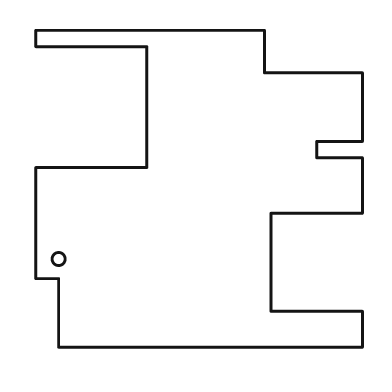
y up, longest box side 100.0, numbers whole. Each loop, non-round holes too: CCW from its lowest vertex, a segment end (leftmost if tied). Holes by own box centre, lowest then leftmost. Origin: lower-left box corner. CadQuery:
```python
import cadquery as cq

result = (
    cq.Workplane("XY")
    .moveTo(7.0, 0.0)
    .lineTo(100.0, 0.0)
    .lineTo(100.0, 11.0)
    .lineTo(72.0, 11.0)
    .lineTo(72.0, 41.0)
    .lineTo(100.0, 41.0)
    .lineTo(100.0, 58.0)
    .lineTo(86.0, 58.0)
    .lineTo(86.0, 63.0)
    .lineTo(100.0, 63.0)
    .lineTo(100.0, 84.0)
    .lineTo(70.0, 84.0)
    .lineTo(70.0, 97.0)
    .lineTo(0.0, 97.0)
    .lineTo(0.0, 92.0)
    .lineTo(34.0, 92.0)
    .lineTo(34.0, 55.0)
    .lineTo(0.0, 55.0)
    .lineTo(0.0, 21.0)
    .lineTo(7.0, 21.0)
    .close()
    .moveTo(7.0, 27.0)
    .circle(2.0)
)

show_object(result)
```